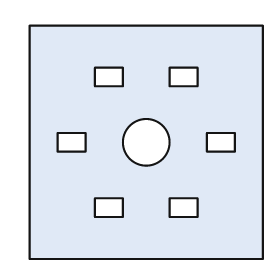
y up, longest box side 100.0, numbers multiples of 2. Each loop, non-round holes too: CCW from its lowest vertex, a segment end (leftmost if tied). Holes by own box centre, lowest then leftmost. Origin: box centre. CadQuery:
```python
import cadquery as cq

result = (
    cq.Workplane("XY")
    .moveTo(-50.0, -50.0)
    .lineTo(50.0, -50.0)
    .lineTo(50.0, 50.0)
    .lineTo(-50.0, 50.0)
    .close()
    .moveTo(-22.0, -32.0)
    .lineTo(-10.0, -32.0)
    .lineTo(-10.0, -24.0)
    .lineTo(-22.0, -24.0)
    .close()
    .moveTo(10.0, -32.0)
    .lineTo(22.0, -32.0)
    .lineTo(22.0, -24.0)
    .lineTo(10.0, -24.0)
    .close()
    .moveTo(-38.0, -4.0)
    .lineTo(-26.0, -4.0)
    .lineTo(-26.0, 4.0)
    .lineTo(-38.0, 4.0)
    .close()
    .moveTo(0.0, 0.0)
    .circle(10.0)
    .moveTo(26.0, -4.0)
    .lineTo(38.0, -4.0)
    .lineTo(38.0, 4.0)
    .lineTo(26.0, 4.0)
    .close()
    .moveTo(-22.0, 24.0)
    .lineTo(-10.0, 24.0)
    .lineTo(-10.0, 32.0)
    .lineTo(-22.0, 32.0)
    .close()
    .moveTo(10.0, 24.0)
    .lineTo(22.0, 24.0)
    .lineTo(22.0, 32.0)
    .lineTo(10.0, 32.0)
    .close()
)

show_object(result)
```